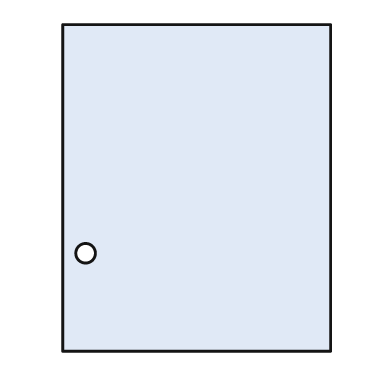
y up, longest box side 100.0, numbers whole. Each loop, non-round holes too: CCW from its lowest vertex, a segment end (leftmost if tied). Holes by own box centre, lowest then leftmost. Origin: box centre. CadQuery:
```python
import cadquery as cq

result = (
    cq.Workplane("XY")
    .moveTo(-41.0, -50.0)
    .lineTo(41.0, -50.0)
    .lineTo(41.0, 50.0)
    .lineTo(-41.0, 50.0)
    .close()
    .moveTo(-34.0, -20.0)
    .circle(3.0)
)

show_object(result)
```